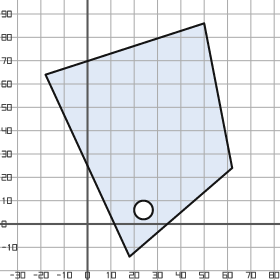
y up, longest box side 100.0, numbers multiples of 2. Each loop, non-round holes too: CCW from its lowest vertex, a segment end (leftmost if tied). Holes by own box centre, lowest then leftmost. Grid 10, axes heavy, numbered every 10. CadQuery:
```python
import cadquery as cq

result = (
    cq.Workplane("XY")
    .moveTo(18.0, -14.0)
    .lineTo(62.0, 24.0)
    .lineTo(50.0, 86.0)
    .lineTo(-18.0, 64.0)
    .close()
    .moveTo(24.0, 6.0)
    .circle(4.0)
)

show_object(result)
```